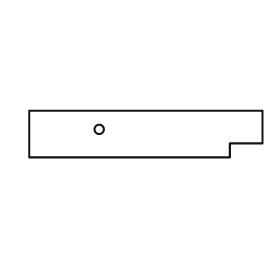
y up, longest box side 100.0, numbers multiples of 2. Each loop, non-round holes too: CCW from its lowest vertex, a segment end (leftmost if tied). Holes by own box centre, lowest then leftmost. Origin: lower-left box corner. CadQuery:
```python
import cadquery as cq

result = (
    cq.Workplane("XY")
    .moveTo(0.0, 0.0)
    .lineTo(86.0, 0.0)
    .lineTo(86.0, 6.0)
    .lineTo(100.0, 6.0)
    .lineTo(100.0, 20.0)
    .lineTo(0.0, 20.0)
    .close()
    .moveTo(30.0, 12.0)
    .circle(2.0)
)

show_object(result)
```